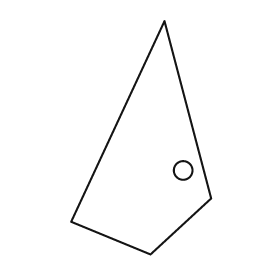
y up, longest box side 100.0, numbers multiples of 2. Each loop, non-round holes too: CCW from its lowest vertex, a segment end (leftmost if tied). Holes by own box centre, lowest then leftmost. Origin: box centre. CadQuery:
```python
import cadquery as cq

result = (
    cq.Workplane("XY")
    .moveTo(4.0, -50.0)
    .lineTo(30.0, -26.0)
    .lineTo(10.0, 50.0)
    .lineTo(-30.0, -36.0)
    .close()
    .moveTo(18.0, -14.0)
    .circle(4.0)
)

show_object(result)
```